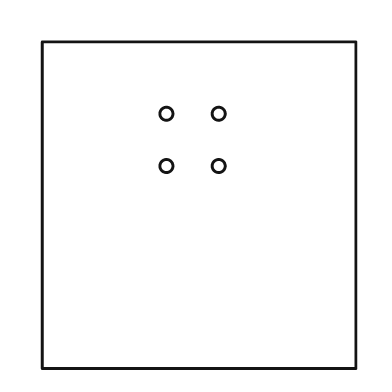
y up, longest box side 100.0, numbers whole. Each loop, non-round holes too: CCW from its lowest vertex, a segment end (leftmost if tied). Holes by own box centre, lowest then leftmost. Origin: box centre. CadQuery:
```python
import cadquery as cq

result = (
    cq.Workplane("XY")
    .moveTo(-48.0, -50.0)
    .lineTo(48.0, -50.0)
    .lineTo(48.0, 50.0)
    .lineTo(-48.0, 50.0)
    .close()
    .moveTo(-10.0, 12.0)
    .circle(2.0)
    .moveTo(6.0, 12.0)
    .circle(2.0)
    .moveTo(-10.0, 28.0)
    .circle(2.0)
    .moveTo(6.0, 28.0)
    .circle(2.0)
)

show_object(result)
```